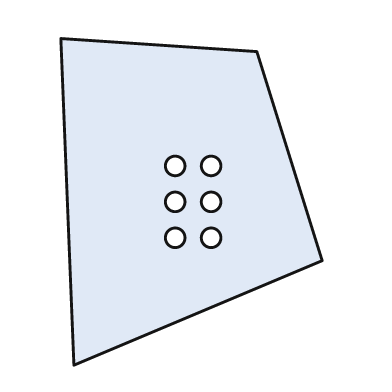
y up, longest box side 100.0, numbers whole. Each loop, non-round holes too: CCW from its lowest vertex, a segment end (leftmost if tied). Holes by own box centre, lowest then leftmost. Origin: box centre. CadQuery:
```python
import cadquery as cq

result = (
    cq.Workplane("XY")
    .moveTo(-36.0, -50.0)
    .lineTo(40.0, -18.0)
    .lineTo(20.0, 46.0)
    .lineTo(-40.0, 50.0)
    .close()
    .moveTo(-5.0, -11.0)
    .circle(3.0)
    .moveTo(6.0, -11.0)
    .circle(3.0)
    .moveTo(-5.0, 0.0)
    .circle(3.0)
    .moveTo(6.0, 0.0)
    .circle(3.0)
    .moveTo(-5.0, 11.0)
    .circle(3.0)
    .moveTo(6.0, 11.0)
    .circle(3.0)
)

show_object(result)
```